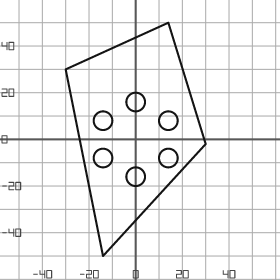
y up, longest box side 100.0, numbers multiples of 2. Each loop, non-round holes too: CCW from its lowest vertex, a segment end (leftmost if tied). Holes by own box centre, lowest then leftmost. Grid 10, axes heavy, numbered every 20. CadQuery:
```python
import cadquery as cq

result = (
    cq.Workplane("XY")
    .moveTo(-14.0, -50.0)
    .lineTo(30.0, -2.0)
    .lineTo(14.0, 50.0)
    .lineTo(-30.0, 30.0)
    .close()
    .moveTo(0.0, -16.0)
    .circle(4.0)
    .moveTo(-14.0, -8.0)
    .circle(4.0)
    .moveTo(14.0, -8.0)
    .circle(4.0)
    .moveTo(-14.0, 8.0)
    .circle(4.0)
    .moveTo(14.0, 8.0)
    .circle(4.0)
    .moveTo(0.0, 16.0)
    .circle(4.0)
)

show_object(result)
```